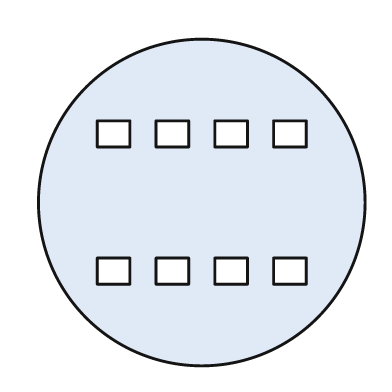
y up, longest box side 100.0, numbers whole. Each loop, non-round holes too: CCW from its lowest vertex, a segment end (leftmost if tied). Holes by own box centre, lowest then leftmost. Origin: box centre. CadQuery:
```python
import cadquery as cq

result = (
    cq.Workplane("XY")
    .moveTo(0.0, 0.0)
    .circle(50.0)
    .moveTo(-32.0, -25.0)
    .lineTo(-22.0, -25.0)
    .lineTo(-22.0, -17.0)
    .lineTo(-32.0, -17.0)
    .close()
    .moveTo(-14.0, -25.0)
    .lineTo(-4.0, -25.0)
    .lineTo(-4.0, -17.0)
    .lineTo(-14.0, -17.0)
    .close()
    .moveTo(4.0, -25.0)
    .lineTo(14.0, -25.0)
    .lineTo(14.0, -17.0)
    .lineTo(4.0, -17.0)
    .close()
    .moveTo(22.0, -25.0)
    .lineTo(32.0, -25.0)
    .lineTo(32.0, -17.0)
    .lineTo(22.0, -17.0)
    .close()
    .moveTo(-32.0, 17.0)
    .lineTo(-22.0, 17.0)
    .lineTo(-22.0, 25.0)
    .lineTo(-32.0, 25.0)
    .close()
    .moveTo(-14.0, 17.0)
    .lineTo(-4.0, 17.0)
    .lineTo(-4.0, 25.0)
    .lineTo(-14.0, 25.0)
    .close()
    .moveTo(4.0, 17.0)
    .lineTo(14.0, 17.0)
    .lineTo(14.0, 25.0)
    .lineTo(4.0, 25.0)
    .close()
    .moveTo(22.0, 17.0)
    .lineTo(32.0, 17.0)
    .lineTo(32.0, 25.0)
    .lineTo(22.0, 25.0)
    .close()
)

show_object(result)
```